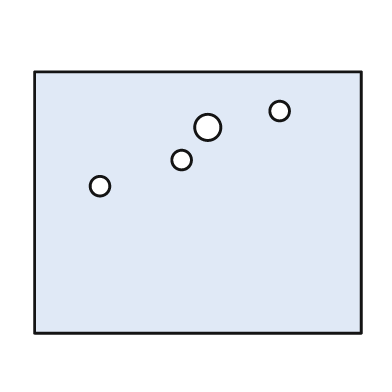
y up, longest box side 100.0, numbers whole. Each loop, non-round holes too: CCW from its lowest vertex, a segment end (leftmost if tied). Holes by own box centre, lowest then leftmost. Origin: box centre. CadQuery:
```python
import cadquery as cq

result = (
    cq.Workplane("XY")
    .moveTo(-50.0, -40.0)
    .lineTo(50.0, -40.0)
    .lineTo(50.0, 40.0)
    .lineTo(-50.0, 40.0)
    .close()
    .moveTo(-30.0, 5.0)
    .circle(3.0)
    .moveTo(-5.0, 13.0)
    .circle(3.0)
    .moveTo(3.0, 23.0)
    .circle(4.0)
    .moveTo(25.0, 28.0)
    .circle(3.0)
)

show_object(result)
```